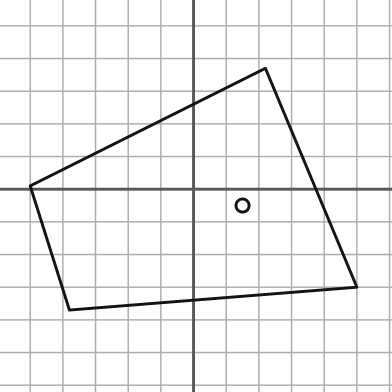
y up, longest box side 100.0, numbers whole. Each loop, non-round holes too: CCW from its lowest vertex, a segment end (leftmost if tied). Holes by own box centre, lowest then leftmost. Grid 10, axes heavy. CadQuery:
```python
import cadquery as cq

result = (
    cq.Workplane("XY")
    .moveTo(-38.0, -37.0)
    .lineTo(50.0, -30.0)
    .lineTo(22.0, 37.0)
    .lineTo(-50.0, 1.0)
    .close()
    .moveTo(15.0, -5.0)
    .circle(2.0)
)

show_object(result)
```